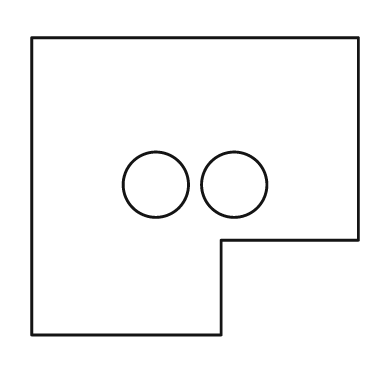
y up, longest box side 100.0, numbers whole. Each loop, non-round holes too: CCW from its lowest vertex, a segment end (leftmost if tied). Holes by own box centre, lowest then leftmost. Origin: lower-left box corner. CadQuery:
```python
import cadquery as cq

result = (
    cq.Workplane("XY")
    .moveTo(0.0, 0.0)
    .lineTo(58.0, 0.0)
    .lineTo(58.0, 29.0)
    .lineTo(100.0, 29.0)
    .lineTo(100.0, 91.0)
    .lineTo(0.0, 91.0)
    .close()
    .moveTo(38.0, 46.0)
    .circle(10.0)
    .moveTo(62.0, 46.0)
    .circle(10.0)
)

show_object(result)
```